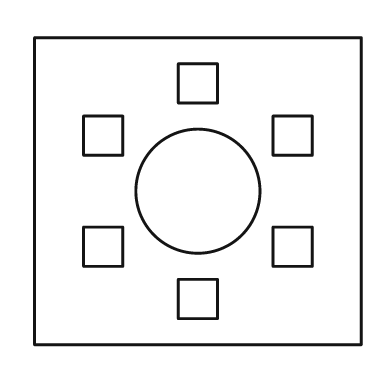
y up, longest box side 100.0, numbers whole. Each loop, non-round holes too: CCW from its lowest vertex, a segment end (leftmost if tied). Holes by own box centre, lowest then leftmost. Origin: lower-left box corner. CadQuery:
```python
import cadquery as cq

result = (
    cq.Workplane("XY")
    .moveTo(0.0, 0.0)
    .lineTo(100.0, 0.0)
    .lineTo(100.0, 94.0)
    .lineTo(0.0, 94.0)
    .close()
    .moveTo(44.0, 8.0)
    .lineTo(56.0, 8.0)
    .lineTo(56.0, 20.0)
    .lineTo(44.0, 20.0)
    .close()
    .moveTo(15.0, 24.0)
    .lineTo(27.0, 24.0)
    .lineTo(27.0, 36.0)
    .lineTo(15.0, 36.0)
    .close()
    .moveTo(73.0, 24.0)
    .lineTo(85.0, 24.0)
    .lineTo(85.0, 36.0)
    .lineTo(73.0, 36.0)
    .close()
    .moveTo(50.0, 47.0)
    .circle(19.0)
    .moveTo(15.0, 58.0)
    .lineTo(27.0, 58.0)
    .lineTo(27.0, 70.0)
    .lineTo(15.0, 70.0)
    .close()
    .moveTo(73.0, 58.0)
    .lineTo(85.0, 58.0)
    .lineTo(85.0, 70.0)
    .lineTo(73.0, 70.0)
    .close()
    .moveTo(44.0, 74.0)
    .lineTo(56.0, 74.0)
    .lineTo(56.0, 86.0)
    .lineTo(44.0, 86.0)
    .close()
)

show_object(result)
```